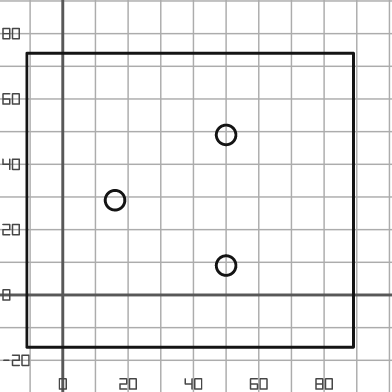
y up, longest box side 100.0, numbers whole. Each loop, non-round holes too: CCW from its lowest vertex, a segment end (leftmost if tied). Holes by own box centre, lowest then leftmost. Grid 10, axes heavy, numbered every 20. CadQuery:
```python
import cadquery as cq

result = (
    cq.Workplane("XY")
    .moveTo(-11.0, -16.0)
    .lineTo(89.0, -16.0)
    .lineTo(89.0, 74.0)
    .lineTo(-11.0, 74.0)
    .close()
    .moveTo(50.0, 9.0)
    .circle(3.0)
    .moveTo(16.0, 29.0)
    .circle(3.0)
    .moveTo(50.0, 49.0)
    .circle(3.0)
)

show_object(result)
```